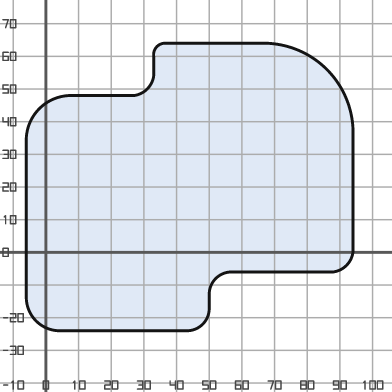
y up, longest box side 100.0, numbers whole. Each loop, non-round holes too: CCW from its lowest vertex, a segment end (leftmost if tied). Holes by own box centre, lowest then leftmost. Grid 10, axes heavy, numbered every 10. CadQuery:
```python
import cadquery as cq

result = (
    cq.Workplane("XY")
    .moveTo(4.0, -24.0)
    .lineTo(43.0, -24.0)
    .threePointArc((48.0, -22.0), (50.0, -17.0))
    .lineTo(50.0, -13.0)
    .threePointArc((52.0, -8.0), (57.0, -6.0))
    .lineTo(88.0, -6.0)
    .threePointArc((92.0, -4.0), (94.0, 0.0))
    .lineTo(94.0, 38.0)
    .threePointArc((86.0, 56.0), (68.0, 64.0))
    .lineTo(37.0, 64.0)
    .threePointArc((34.0, 63.0), (33.0, 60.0))
    .lineTo(33.0, 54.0)
    .threePointArc((31.0, 50.0), (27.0, 48.0))
    .lineTo(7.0, 48.0)
    .threePointArc((-2.0, 44.0), (-6.0, 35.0))
    .lineTo(-6.0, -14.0)
    .threePointArc((-3.0, -21.0), (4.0, -24.0))
    .close()
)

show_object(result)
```